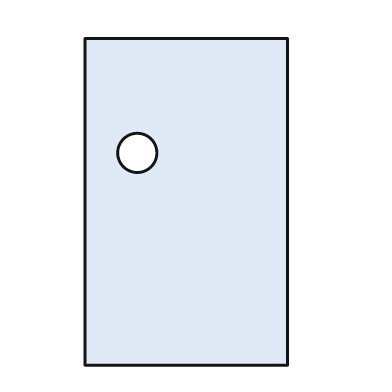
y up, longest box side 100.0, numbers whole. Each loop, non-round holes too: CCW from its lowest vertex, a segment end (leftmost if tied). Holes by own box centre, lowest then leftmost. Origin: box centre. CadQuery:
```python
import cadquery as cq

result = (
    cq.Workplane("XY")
    .moveTo(-31.0, -50.0)
    .lineTo(31.0, -50.0)
    .lineTo(31.0, 50.0)
    .lineTo(-31.0, 50.0)
    .close()
    .moveTo(-15.0, 15.0)
    .circle(6.0)
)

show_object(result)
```